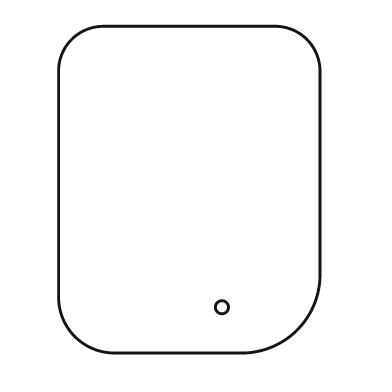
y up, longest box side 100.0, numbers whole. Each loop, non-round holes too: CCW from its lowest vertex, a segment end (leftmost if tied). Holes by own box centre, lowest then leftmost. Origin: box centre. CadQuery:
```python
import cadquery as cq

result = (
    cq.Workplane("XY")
    .moveTo(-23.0, -50.0)
    .lineTo(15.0, -50.0)
    .threePointArc((33.0, -43.0), (40.0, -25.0))
    .lineTo(40.0, 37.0)
    .threePointArc((36.0, 46.0), (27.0, 50.0))
    .lineTo(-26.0, 50.0)
    .threePointArc((-36.0, 46.0), (-40.0, 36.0))
    .lineTo(-40.0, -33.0)
    .threePointArc((-35.0, -45.0), (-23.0, -50.0))
    .close()
    .moveTo(10.0, -36.0)
    .circle(2.0)
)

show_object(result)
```